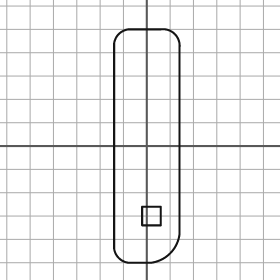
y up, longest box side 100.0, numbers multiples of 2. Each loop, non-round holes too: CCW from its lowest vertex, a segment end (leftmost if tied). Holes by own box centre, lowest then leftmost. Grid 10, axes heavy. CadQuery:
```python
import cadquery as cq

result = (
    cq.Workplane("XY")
    .moveTo(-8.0, -50.0)
    .lineTo(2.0, -50.0)
    .threePointArc((10.0, -46.0), (14.0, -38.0))
    .lineTo(14.0, 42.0)
    .threePointArc((12.0, 48.0), (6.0, 50.0))
    .lineTo(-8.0, 50.0)
    .threePointArc((-12.0, 48.0), (-14.0, 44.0))
    .lineTo(-14.0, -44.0)
    .threePointArc((-12.0, -48.0), (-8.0, -50.0))
    .close()
    .moveTo(-2.0, -34.0)
    .lineTo(6.0, -34.0)
    .lineTo(6.0, -26.0)
    .lineTo(-2.0, -26.0)
    .close()
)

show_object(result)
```